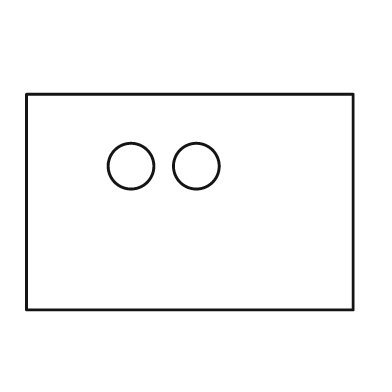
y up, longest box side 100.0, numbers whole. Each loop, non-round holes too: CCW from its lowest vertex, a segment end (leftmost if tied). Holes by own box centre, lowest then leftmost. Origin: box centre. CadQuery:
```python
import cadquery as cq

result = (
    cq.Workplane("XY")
    .moveTo(-50.0, -33.0)
    .lineTo(50.0, -33.0)
    .lineTo(50.0, 33.0)
    .lineTo(-50.0, 33.0)
    .close()
    .moveTo(-18.0, 11.0)
    .circle(7.0)
    .moveTo(2.0, 11.0)
    .circle(7.0)
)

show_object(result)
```